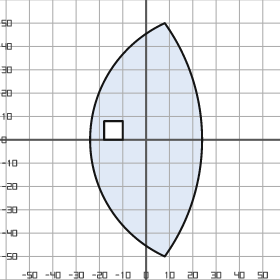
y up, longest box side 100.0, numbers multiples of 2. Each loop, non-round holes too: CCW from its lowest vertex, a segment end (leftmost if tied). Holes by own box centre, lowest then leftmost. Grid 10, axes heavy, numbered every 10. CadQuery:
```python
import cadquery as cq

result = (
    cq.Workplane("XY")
    .moveTo(8.0, -50.0)
    .threePointArc((24.0, 0.0), (8.0, 50.0))
    .threePointArc((-24.0, 0.0), (8.0, -50.0))
    .close()
    .moveTo(-18.0, 0.0)
    .lineTo(-10.0, 0.0)
    .lineTo(-10.0, 8.0)
    .lineTo(-18.0, 8.0)
    .close()
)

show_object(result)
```